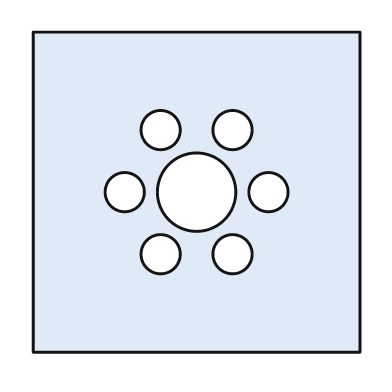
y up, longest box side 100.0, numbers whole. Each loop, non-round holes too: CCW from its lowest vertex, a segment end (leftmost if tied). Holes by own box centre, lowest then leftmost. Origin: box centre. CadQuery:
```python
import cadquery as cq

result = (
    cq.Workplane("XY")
    .moveTo(-50.0, -49.0)
    .lineTo(50.0, -49.0)
    .lineTo(50.0, 49.0)
    .lineTo(-50.0, 49.0)
    .close()
    .moveTo(-11.0, -19.0)
    .circle(6.0)
    .moveTo(11.0, -19.0)
    .circle(6.0)
    .moveTo(-22.0, 0.0)
    .circle(6.0)
    .moveTo(0.0, 0.0)
    .circle(12.0)
    .moveTo(22.0, 0.0)
    .circle(6.0)
    .moveTo(-11.0, 19.0)
    .circle(6.0)
    .moveTo(11.0, 19.0)
    .circle(6.0)
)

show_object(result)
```